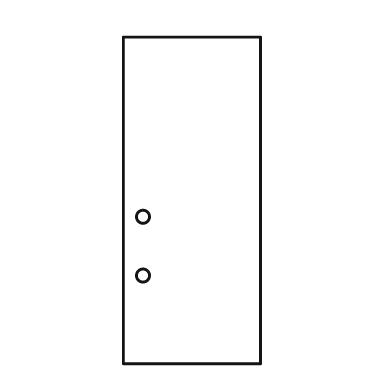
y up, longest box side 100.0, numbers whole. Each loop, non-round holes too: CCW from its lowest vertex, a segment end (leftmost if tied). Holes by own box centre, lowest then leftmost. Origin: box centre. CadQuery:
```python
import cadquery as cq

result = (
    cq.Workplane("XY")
    .moveTo(-21.0, -50.0)
    .lineTo(21.0, -50.0)
    .lineTo(21.0, 50.0)
    .lineTo(-21.0, 50.0)
    .close()
    .moveTo(-15.0, -23.0)
    .circle(2.0)
    .moveTo(-15.0, -5.0)
    .circle(2.0)
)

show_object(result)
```